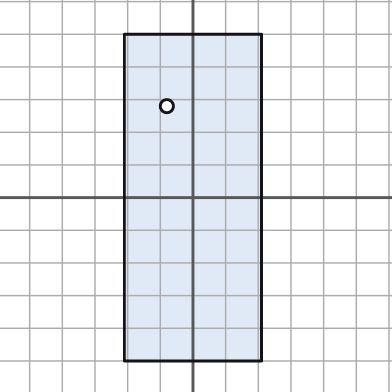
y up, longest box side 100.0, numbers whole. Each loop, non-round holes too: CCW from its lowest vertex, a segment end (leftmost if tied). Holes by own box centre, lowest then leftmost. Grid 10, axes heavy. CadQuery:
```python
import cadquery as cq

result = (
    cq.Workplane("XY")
    .moveTo(-21.0, -50.0)
    .lineTo(21.0, -50.0)
    .lineTo(21.0, 50.0)
    .lineTo(-21.0, 50.0)
    .close()
    .moveTo(-8.0, 28.0)
    .circle(2.0)
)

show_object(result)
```